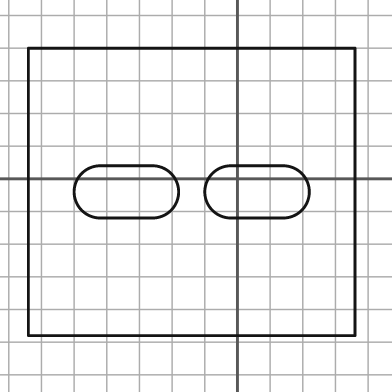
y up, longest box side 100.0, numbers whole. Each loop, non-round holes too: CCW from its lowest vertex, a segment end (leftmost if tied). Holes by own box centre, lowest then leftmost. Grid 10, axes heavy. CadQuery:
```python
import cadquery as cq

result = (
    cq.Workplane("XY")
    .moveTo(-64.0, -48.0)
    .lineTo(36.0, -48.0)
    .lineTo(36.0, 40.0)
    .lineTo(-64.0, 40.0)
    .close()
    .moveTo(-42.0, -12.0)
    .lineTo(-26.0, -12.0)
    .threePointArc((-18.0, -4.0), (-26.0, 4.0))
    .lineTo(-42.0, 4.0)
    .threePointArc((-50.0, -4.0), (-42.0, -12.0))
    .close()
    .moveTo(-2.0, -12.0)
    .lineTo(14.0, -12.0)
    .threePointArc((22.0, -4.0), (14.0, 4.0))
    .lineTo(-2.0, 4.0)
    .threePointArc((-10.0, -4.0), (-2.0, -12.0))
    .close()
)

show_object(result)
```